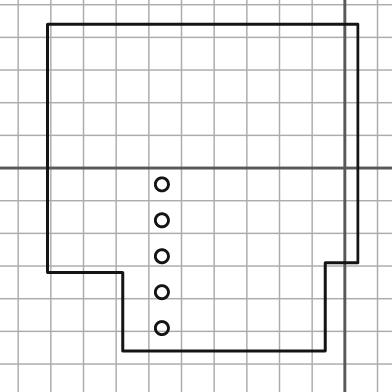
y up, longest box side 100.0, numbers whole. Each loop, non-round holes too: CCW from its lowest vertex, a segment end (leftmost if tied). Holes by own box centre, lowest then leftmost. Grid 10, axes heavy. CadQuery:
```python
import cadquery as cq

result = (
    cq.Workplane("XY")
    .moveTo(-68.0, -56.0)
    .lineTo(-6.0, -56.0)
    .lineTo(-6.0, -29.0)
    .lineTo(4.0, -29.0)
    .lineTo(4.0, 44.0)
    .lineTo(-91.0, 44.0)
    .lineTo(-91.0, -32.0)
    .lineTo(-68.0, -32.0)
    .close()
    .moveTo(-56.0, -49.0)
    .circle(2.0)
    .moveTo(-56.0, -38.0)
    .circle(2.0)
    .moveTo(-56.0, -27.0)
    .circle(2.0)
    .moveTo(-56.0, -16.0)
    .circle(2.0)
    .moveTo(-56.0, -5.0)
    .circle(2.0)
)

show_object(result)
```